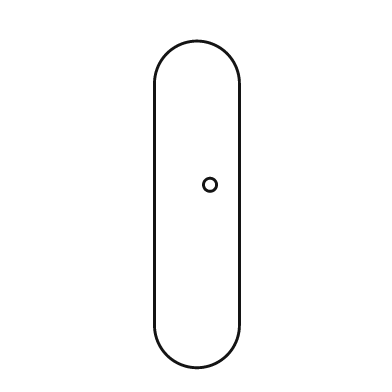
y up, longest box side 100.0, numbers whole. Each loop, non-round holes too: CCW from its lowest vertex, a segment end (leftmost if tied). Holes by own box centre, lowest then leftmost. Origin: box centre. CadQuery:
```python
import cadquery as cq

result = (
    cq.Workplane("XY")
    .moveTo(-13.0, -37.0)
    .threePointArc((0.0, -50.0), (13.0, -37.0))
    .lineTo(13.0, 37.0)
    .threePointArc((0.0, 50.0), (-13.0, 37.0))
    .close()
    .moveTo(4.0, 6.0)
    .circle(2.0)
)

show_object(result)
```